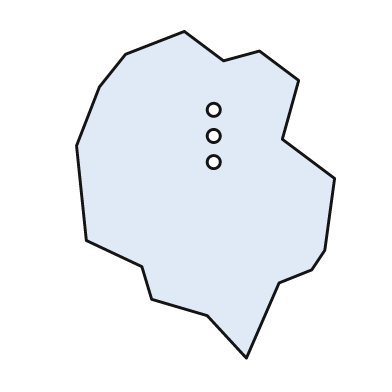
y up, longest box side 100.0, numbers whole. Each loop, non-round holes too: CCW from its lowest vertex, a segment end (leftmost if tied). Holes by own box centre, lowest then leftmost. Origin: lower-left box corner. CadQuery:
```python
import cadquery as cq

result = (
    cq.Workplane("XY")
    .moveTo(52.0, 0.0)
    .lineTo(62.0, 23.0)
    .lineTo(72.0, 27.0)
    .lineTo(76.0, 33.0)
    .lineTo(79.0, 55.0)
    .lineTo(63.0, 67.0)
    .lineTo(68.0, 85.0)
    .lineTo(56.0, 94.0)
    .lineTo(45.0, 91.0)
    .lineTo(33.0, 100.0)
    .lineTo(15.0, 93.0)
    .lineTo(7.0, 83.0)
    .lineTo(0.0, 65.0)
    .lineTo(3.0, 36.0)
    .lineTo(20.0, 28.0)
    .lineTo(23.0, 18.0)
    .lineTo(40.0, 13.0)
    .close()
    .moveTo(42.0, 60.0)
    .circle(2.0)
    .moveTo(42.0, 68.0)
    .circle(2.0)
    .moveTo(42.0, 76.0)
    .circle(2.0)
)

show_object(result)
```